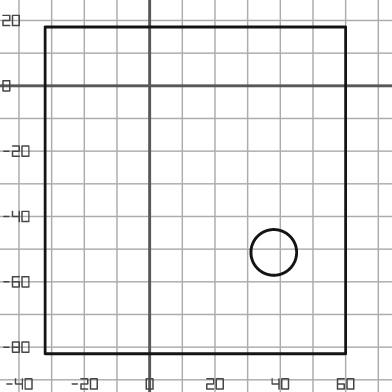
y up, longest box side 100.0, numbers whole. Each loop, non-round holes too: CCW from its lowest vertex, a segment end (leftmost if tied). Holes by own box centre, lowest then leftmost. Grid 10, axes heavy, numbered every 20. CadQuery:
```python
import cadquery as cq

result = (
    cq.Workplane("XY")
    .moveTo(-32.0, -82.0)
    .lineTo(60.0, -82.0)
    .lineTo(60.0, 18.0)
    .lineTo(-32.0, 18.0)
    .close()
    .moveTo(38.0, -51.0)
    .circle(7.0)
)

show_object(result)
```